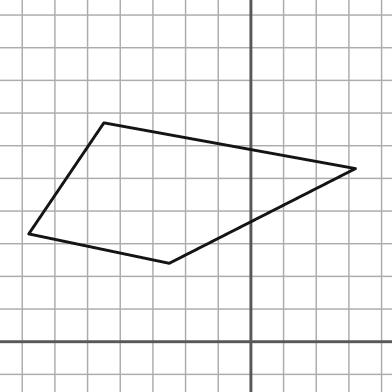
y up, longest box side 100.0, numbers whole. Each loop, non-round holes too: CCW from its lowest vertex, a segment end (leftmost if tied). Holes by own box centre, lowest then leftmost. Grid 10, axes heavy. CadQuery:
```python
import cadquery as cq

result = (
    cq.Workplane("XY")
    .moveTo(-25.0, 24.0)
    .lineTo(32.0, 53.0)
    .lineTo(-45.0, 67.0)
    .lineTo(-68.0, 33.0)
    .close()
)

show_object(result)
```